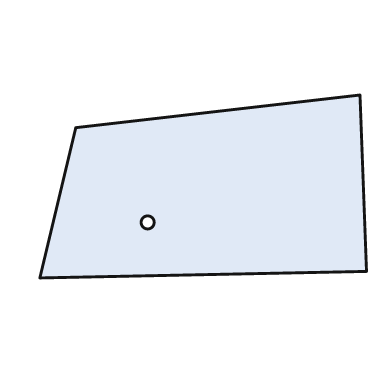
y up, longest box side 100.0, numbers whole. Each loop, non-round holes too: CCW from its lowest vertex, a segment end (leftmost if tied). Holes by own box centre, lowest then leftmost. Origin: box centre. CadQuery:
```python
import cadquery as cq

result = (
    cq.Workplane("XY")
    .moveTo(-50.0, -28.0)
    .lineTo(50.0, -26.0)
    .lineTo(48.0, 28.0)
    .lineTo(-39.0, 18.0)
    .close()
    .moveTo(-17.0, -11.0)
    .circle(2.0)
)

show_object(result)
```